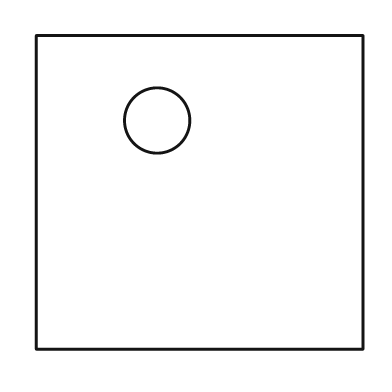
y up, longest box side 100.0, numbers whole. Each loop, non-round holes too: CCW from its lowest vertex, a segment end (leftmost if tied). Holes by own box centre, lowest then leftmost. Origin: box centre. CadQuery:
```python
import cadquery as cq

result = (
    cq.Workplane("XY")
    .moveTo(-50.0, -48.0)
    .lineTo(50.0, -48.0)
    .lineTo(50.0, 48.0)
    .lineTo(-50.0, 48.0)
    .close()
    .moveTo(-13.0, 22.0)
    .circle(10.0)
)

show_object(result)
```